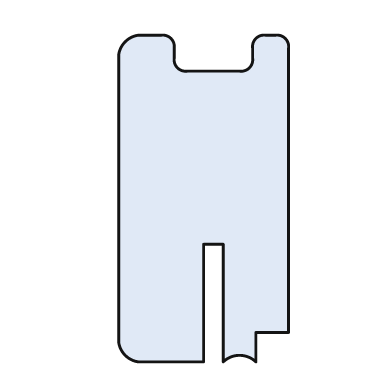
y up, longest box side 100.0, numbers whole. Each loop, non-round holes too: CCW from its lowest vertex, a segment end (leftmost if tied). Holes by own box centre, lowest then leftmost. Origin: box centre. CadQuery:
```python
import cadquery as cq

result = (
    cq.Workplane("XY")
    .moveTo(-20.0, -50.0)
    .lineTo(0.0, -50.0)
    .lineTo(0.0, -14.0)
    .lineTo(6.0, -14.0)
    .lineTo(6.0, -50.0)
    .threePointArc((11.0, -48.0), (16.0, -50.0))
    .lineTo(16.0, -41.0)
    .lineTo(26.0, -41.0)
    .lineTo(26.0, 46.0)
    .threePointArc((25.0, 49.0), (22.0, 50.0))
    .lineTo(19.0, 50.0)
    .threePointArc((16.0, 49.0), (15.0, 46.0))
    .lineTo(15.0, 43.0)
    .threePointArc((14.0, 40.0), (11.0, 39.0))
    .lineTo(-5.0, 39.0)
    .threePointArc((-8.0, 40.0), (-9.0, 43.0))
    .lineTo(-9.0, 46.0)
    .threePointArc((-10.0, 49.0), (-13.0, 50.0))
    .lineTo(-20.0, 50.0)
    .threePointArc((-24.0, 48.0), (-26.0, 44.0))
    .lineTo(-26.0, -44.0)
    .threePointArc((-24.0, -48.0), (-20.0, -50.0))
    .close()
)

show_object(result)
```